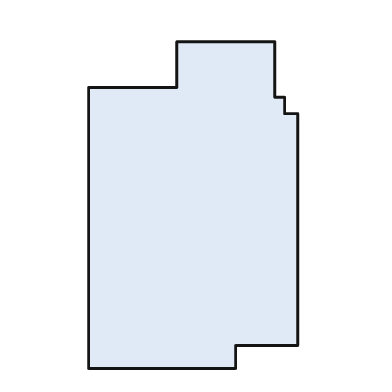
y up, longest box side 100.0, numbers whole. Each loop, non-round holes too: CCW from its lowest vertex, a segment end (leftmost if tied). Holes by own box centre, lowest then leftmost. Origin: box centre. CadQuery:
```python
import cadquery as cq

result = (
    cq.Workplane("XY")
    .moveTo(-32.0, -50.0)
    .lineTo(13.0, -50.0)
    .lineTo(13.0, -43.0)
    .lineTo(32.0, -43.0)
    .lineTo(32.0, 28.0)
    .lineTo(28.0, 28.0)
    .lineTo(28.0, 33.0)
    .lineTo(25.0, 33.0)
    .lineTo(25.0, 50.0)
    .lineTo(-5.0, 50.0)
    .lineTo(-5.0, 36.0)
    .lineTo(-32.0, 36.0)
    .close()
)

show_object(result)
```